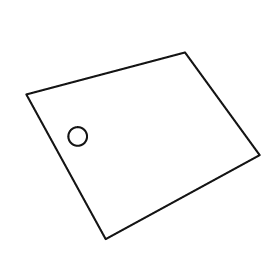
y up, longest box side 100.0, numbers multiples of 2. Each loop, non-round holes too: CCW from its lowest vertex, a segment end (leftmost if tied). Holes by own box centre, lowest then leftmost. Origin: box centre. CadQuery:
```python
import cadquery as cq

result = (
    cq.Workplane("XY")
    .moveTo(-16.0, -40.0)
    .lineTo(50.0, -4.0)
    .lineTo(18.0, 40.0)
    .lineTo(-50.0, 22.0)
    .close()
    .moveTo(-28.0, 4.0)
    .circle(4.0)
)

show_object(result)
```